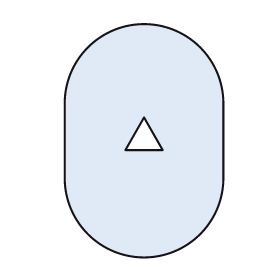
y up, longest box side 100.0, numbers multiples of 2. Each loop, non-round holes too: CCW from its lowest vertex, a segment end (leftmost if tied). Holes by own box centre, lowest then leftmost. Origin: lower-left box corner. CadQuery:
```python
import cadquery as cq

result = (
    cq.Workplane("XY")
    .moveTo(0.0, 34.0)
    .threePointArc((34.0, 0.0), (68.0, 34.0))
    .lineTo(68.0, 66.0)
    .threePointArc((34.0, 100.0), (0.0, 66.0))
    .close()
    .moveTo(26.0, 46.0)
    .lineTo(42.0, 46.0)
    .lineTo(34.0, 60.0)
    .close()
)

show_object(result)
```